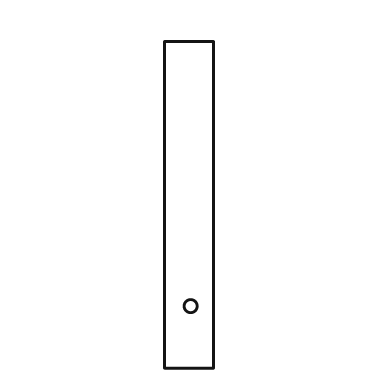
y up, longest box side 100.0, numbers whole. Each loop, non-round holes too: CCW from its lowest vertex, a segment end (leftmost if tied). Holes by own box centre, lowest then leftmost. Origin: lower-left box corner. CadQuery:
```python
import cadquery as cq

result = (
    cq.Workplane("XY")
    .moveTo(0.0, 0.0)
    .lineTo(15.0, 0.0)
    .lineTo(15.0, 100.0)
    .lineTo(0.0, 100.0)
    .close()
    .moveTo(8.0, 19.0)
    .circle(2.0)
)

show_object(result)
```